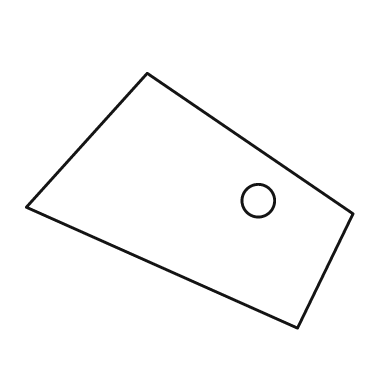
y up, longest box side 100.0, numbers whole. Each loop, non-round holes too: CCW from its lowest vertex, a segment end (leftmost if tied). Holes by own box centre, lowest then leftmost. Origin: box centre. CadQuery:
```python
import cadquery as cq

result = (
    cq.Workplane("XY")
    .moveTo(33.0, -39.0)
    .lineTo(50.0, -4.0)
    .lineTo(-13.0, 39.0)
    .lineTo(-50.0, -2.0)
    .close()
    .moveTo(21.0, 0.0)
    .circle(5.0)
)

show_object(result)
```